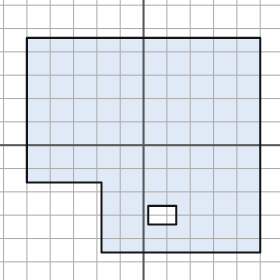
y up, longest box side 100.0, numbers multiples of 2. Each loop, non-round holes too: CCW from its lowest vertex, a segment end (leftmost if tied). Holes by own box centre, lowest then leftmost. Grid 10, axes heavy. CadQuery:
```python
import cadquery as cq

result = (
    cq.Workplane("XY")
    .moveTo(-18.0, -46.0)
    .lineTo(50.0, -46.0)
    .lineTo(50.0, 46.0)
    .lineTo(-50.0, 46.0)
    .lineTo(-50.0, -16.0)
    .lineTo(-18.0, -16.0)
    .close()
    .moveTo(2.0, -34.0)
    .lineTo(14.0, -34.0)
    .lineTo(14.0, -26.0)
    .lineTo(2.0, -26.0)
    .close()
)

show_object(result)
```